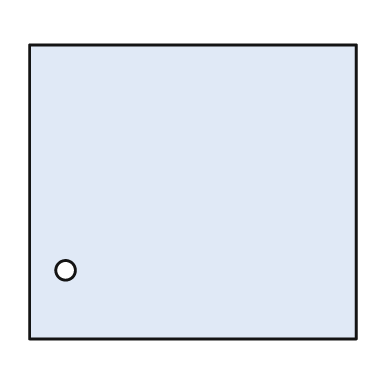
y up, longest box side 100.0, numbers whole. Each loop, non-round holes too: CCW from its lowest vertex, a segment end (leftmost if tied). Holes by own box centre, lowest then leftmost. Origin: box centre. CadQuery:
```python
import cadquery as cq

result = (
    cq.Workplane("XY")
    .moveTo(-50.0, -45.0)
    .lineTo(50.0, -45.0)
    .lineTo(50.0, 45.0)
    .lineTo(-50.0, 45.0)
    .close()
    .moveTo(-39.0, -24.0)
    .circle(3.0)
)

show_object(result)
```